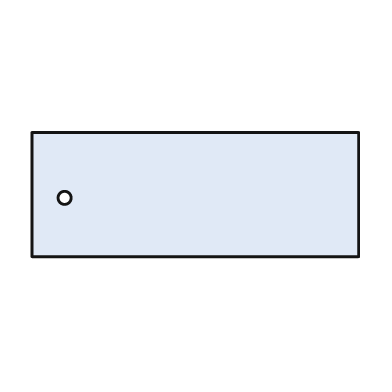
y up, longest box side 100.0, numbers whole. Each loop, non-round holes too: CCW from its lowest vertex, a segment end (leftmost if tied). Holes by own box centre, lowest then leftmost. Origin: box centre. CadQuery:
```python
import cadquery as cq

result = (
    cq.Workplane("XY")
    .moveTo(-50.0, -19.0)
    .lineTo(50.0, -19.0)
    .lineTo(50.0, 19.0)
    .lineTo(-50.0, 19.0)
    .close()
    .moveTo(-40.0, -1.0)
    .circle(2.0)
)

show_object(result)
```